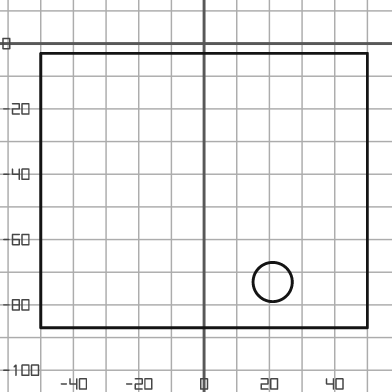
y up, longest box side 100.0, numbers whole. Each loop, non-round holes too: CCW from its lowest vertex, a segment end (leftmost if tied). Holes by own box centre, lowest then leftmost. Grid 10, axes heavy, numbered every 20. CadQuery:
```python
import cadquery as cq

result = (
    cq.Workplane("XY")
    .moveTo(-50.0, -87.0)
    .lineTo(50.0, -87.0)
    .lineTo(50.0, -3.0)
    .lineTo(-50.0, -3.0)
    .close()
    .moveTo(21.0, -73.0)
    .circle(6.0)
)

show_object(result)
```